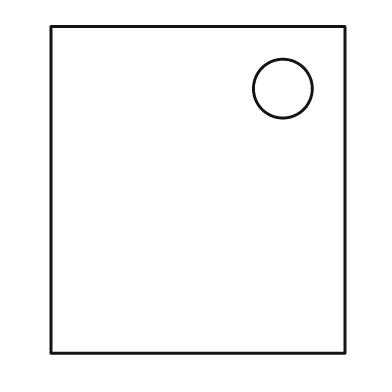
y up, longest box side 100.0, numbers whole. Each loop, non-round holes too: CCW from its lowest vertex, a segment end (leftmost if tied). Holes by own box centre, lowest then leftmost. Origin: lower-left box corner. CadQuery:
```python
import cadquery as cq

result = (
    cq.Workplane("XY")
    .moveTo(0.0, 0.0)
    .lineTo(90.0, 0.0)
    .lineTo(90.0, 100.0)
    .lineTo(0.0, 100.0)
    .close()
    .moveTo(71.0, 81.0)
    .circle(9.0)
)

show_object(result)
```